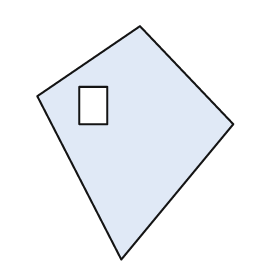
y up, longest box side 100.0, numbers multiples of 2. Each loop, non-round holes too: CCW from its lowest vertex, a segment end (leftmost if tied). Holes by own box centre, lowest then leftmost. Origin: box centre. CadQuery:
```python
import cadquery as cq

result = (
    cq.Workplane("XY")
    .moveTo(-6.0, -50.0)
    .lineTo(42.0, 8.0)
    .lineTo(2.0, 50.0)
    .lineTo(-42.0, 20.0)
    .close()
    .moveTo(-24.0, 8.0)
    .lineTo(-12.0, 8.0)
    .lineTo(-12.0, 24.0)
    .lineTo(-24.0, 24.0)
    .close()
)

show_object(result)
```